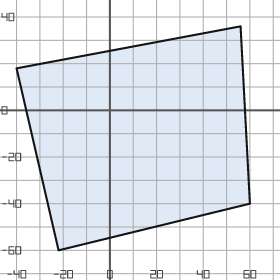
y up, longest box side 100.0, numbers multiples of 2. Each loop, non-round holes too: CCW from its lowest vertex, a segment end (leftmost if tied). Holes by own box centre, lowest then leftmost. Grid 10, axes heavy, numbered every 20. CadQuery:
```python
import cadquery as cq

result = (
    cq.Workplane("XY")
    .moveTo(-22.0, -60.0)
    .lineTo(60.0, -40.0)
    .lineTo(56.0, 36.0)
    .lineTo(-40.0, 18.0)
    .close()
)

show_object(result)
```